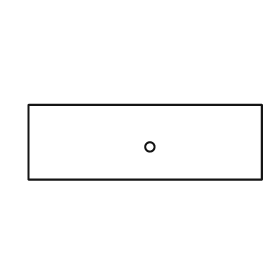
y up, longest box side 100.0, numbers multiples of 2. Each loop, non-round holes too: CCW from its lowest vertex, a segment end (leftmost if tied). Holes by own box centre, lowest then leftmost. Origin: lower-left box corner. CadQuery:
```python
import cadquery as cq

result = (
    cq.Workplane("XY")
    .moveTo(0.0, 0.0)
    .lineTo(100.0, 0.0)
    .lineTo(100.0, 32.0)
    .lineTo(0.0, 32.0)
    .close()
    .moveTo(52.0, 14.0)
    .circle(2.0)
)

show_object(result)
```